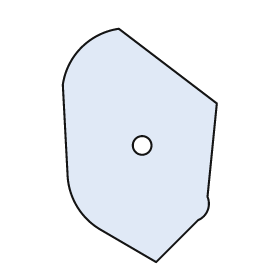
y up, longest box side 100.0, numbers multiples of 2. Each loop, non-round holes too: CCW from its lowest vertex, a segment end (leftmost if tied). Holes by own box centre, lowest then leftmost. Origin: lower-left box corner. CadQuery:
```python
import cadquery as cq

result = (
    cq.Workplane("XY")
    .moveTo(40.0, 0.0)
    .lineTo(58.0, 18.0)
    .threePointArc((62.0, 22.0), (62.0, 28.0))
    .lineTo(66.0, 68.0)
    .lineTo(24.0, 100.0)
    .threePointArc((8.0, 92.0), (0.0, 76.0))
    .lineTo(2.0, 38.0)
    .threePointArc((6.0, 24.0), (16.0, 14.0))
    .close()
    .moveTo(34.0, 50.0)
    .circle(4.0)
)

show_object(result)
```